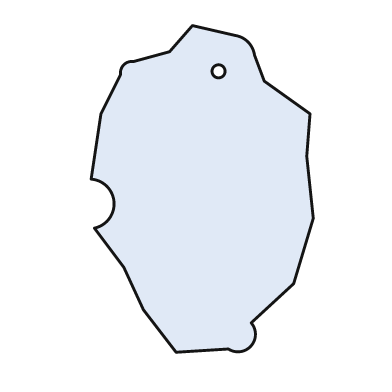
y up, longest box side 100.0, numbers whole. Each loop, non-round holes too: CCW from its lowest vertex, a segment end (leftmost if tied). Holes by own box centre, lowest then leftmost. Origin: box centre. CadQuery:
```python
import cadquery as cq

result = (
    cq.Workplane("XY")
    .moveTo(-8.0, -50.0)
    .lineTo(8.0, -49.0)
    .threePointArc((15.0, -48.0), (15.0, -41.0))
    .lineTo(28.0, -29.0)
    .lineTo(34.0, -9.0)
    .lineTo(32.0, 10.0)
    .lineTo(33.0, 23.0)
    .lineTo(19.0, 33.0)
    .lineTo(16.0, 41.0)
    .threePointArc((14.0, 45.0), (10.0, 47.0))
    .lineTo(-3.0, 50.0)
    .lineTo(-10.0, 42.0)
    .lineTo(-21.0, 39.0)
    .threePointArc((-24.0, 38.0), (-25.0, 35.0))
    .lineTo(-31.0, 23.0)
    .lineTo(-34.0, 3.0)
    .threePointArc((-27.0, -4.0), (-33.0, -12.0))
    .lineTo(-24.0, -24.0)
    .lineTo(-18.0, -37.0)
    .close()
    .moveTo(5.0, 36.0)
    .circle(2.0)
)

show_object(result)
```